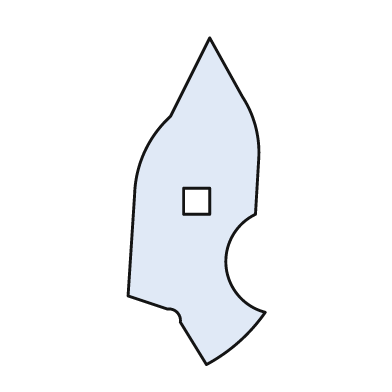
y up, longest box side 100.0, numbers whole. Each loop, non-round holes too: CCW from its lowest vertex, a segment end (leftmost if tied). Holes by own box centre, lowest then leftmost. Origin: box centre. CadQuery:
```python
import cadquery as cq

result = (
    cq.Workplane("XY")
    .moveTo(3.0, -50.0)
    .threePointArc((13.0, -43.0), (21.0, -34.0))
    .threePointArc((9.0, -20.0), (18.0, -4.0))
    .lineTo(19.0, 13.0)
    .threePointArc((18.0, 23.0), (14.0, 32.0))
    .lineTo(4.0, 50.0)
    .lineTo(-8.0, 26.0)
    .threePointArc((-16.0, 15.0), (-19.0, 2.0))
    .lineTo(-21.0, -29.0)
    .lineTo(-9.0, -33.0)
    .threePointArc((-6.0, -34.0), (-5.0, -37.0))
    .close()
    .moveTo(-4.0, -4.0)
    .lineTo(4.0, -4.0)
    .lineTo(4.0, 4.0)
    .lineTo(-4.0, 4.0)
    .close()
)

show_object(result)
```